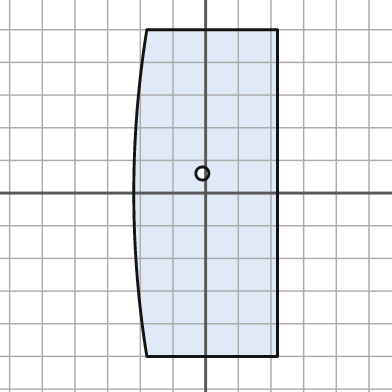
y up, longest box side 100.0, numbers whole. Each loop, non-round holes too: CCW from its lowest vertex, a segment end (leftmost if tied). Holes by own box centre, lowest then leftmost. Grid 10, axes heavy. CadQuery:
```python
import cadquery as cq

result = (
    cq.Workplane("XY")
    .moveTo(-18.0, -50.0)
    .lineTo(22.0, -50.0)
    .lineTo(22.0, 50.0)
    .lineTo(-18.0, 50.0)
    .threePointArc((-22.0, 0.0), (-18.0, -50.0))
    .close()
    .moveTo(-1.0, 6.0)
    .circle(2.0)
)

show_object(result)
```